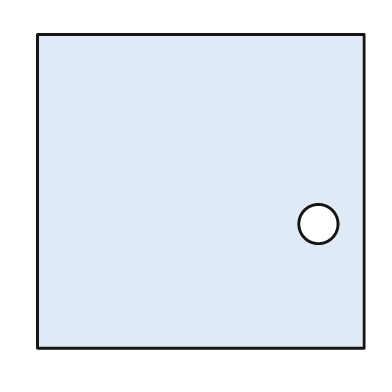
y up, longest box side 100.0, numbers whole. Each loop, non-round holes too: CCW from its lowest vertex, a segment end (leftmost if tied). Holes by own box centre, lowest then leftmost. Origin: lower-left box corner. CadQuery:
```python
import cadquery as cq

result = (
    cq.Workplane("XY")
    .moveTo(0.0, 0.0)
    .lineTo(100.0, 0.0)
    .lineTo(100.0, 96.0)
    .lineTo(0.0, 96.0)
    .close()
    .moveTo(86.0, 38.0)
    .circle(6.0)
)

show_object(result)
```